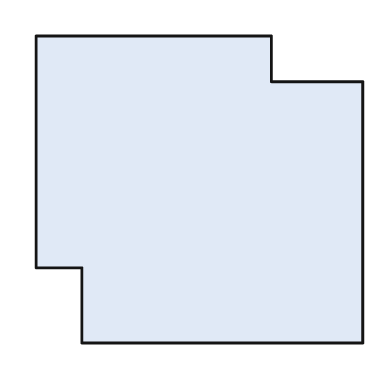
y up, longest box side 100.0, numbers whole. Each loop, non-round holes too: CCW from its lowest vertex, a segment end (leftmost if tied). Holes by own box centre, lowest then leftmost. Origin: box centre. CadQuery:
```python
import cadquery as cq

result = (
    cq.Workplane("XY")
    .moveTo(-36.0, -47.0)
    .lineTo(50.0, -47.0)
    .lineTo(50.0, 33.0)
    .lineTo(22.0, 33.0)
    .lineTo(22.0, 47.0)
    .lineTo(-50.0, 47.0)
    .lineTo(-50.0, -24.0)
    .lineTo(-36.0, -24.0)
    .close()
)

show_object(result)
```